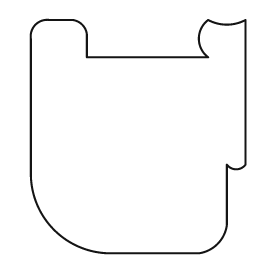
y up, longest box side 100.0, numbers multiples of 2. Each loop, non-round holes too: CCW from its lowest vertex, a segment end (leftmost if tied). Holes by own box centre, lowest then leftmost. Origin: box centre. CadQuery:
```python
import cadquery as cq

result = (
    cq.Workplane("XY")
    .moveTo(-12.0, -50.0)
    .lineTo(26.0, -50.0)
    .threePointArc((34.0, -46.0), (38.0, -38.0))
    .lineTo(38.0, -12.0)
    .threePointArc((42.0, -14.0), (46.0, -12.0))
    .lineTo(46.0, 50.0)
    .threePointArc((38.0, 48.0), (30.0, 50.0))
    .threePointArc((26.0, 42.0), (30.0, 34.0))
    .lineTo(-22.0, 34.0)
    .lineTo(-22.0, 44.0)
    .threePointArc((-24.0, 48.0), (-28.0, 50.0))
    .lineTo(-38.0, 50.0)
    .threePointArc((-44.0, 48.0), (-46.0, 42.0))
    .lineTo(-46.0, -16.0)
    .threePointArc((-36.0, -40.0), (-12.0, -50.0))
    .close()
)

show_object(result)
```